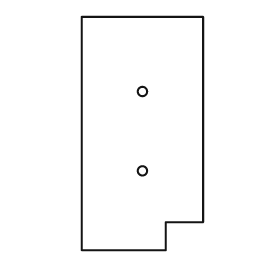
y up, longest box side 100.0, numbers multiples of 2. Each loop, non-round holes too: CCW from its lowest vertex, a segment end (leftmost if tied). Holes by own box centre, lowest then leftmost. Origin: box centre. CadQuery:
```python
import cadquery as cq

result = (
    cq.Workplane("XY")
    .moveTo(-26.0, -50.0)
    .lineTo(10.0, -50.0)
    .lineTo(10.0, -38.0)
    .lineTo(26.0, -38.0)
    .lineTo(26.0, 50.0)
    .lineTo(-26.0, 50.0)
    .close()
    .moveTo(0.0, -16.0)
    .circle(2.0)
    .moveTo(0.0, 18.0)
    .circle(2.0)
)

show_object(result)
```